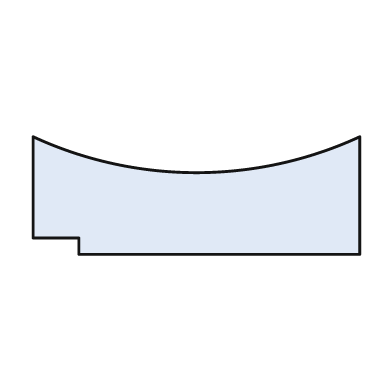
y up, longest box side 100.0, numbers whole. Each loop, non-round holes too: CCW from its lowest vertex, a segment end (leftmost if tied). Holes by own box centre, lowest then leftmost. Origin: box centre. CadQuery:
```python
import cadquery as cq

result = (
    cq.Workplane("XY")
    .moveTo(-36.0, -18.0)
    .lineTo(50.0, -18.0)
    .lineTo(50.0, 18.0)
    .threePointArc((0.0, 7.0), (-50.0, 18.0))
    .lineTo(-50.0, -13.0)
    .lineTo(-36.0, -13.0)
    .close()
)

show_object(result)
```